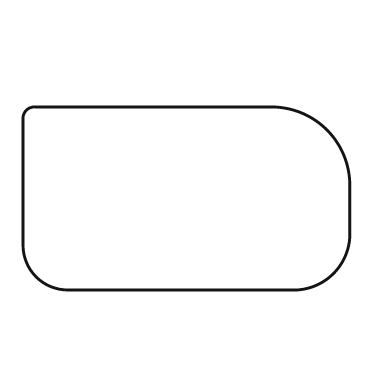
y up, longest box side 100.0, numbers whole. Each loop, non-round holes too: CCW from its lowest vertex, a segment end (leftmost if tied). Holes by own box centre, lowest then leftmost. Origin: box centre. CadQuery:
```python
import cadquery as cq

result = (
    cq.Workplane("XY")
    .moveTo(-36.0, -28.0)
    .lineTo(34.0, -28.0)
    .threePointArc((45.0, -23.0), (50.0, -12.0))
    .lineTo(50.0, 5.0)
    .threePointArc((43.0, 21.0), (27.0, 28.0))
    .lineTo(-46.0, 28.0)
    .threePointArc((-49.0, 27.0), (-50.0, 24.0))
    .lineTo(-50.0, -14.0)
    .threePointArc((-46.0, -24.0), (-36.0, -28.0))
    .close()
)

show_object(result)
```